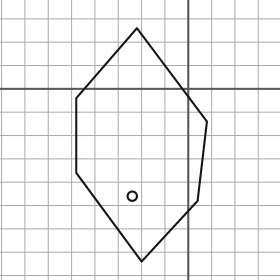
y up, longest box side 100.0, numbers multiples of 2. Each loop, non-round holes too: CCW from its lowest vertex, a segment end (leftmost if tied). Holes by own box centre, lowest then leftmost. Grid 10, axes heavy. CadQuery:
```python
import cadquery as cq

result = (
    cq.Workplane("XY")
    .moveTo(-20.0, -74.0)
    .lineTo(4.0, -48.0)
    .lineTo(8.0, -14.0)
    .lineTo(-22.0, 26.0)
    .lineTo(-48.0, -4.0)
    .lineTo(-48.0, -36.0)
    .close()
    .moveTo(-24.0, -46.0)
    .circle(2.0)
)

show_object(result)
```